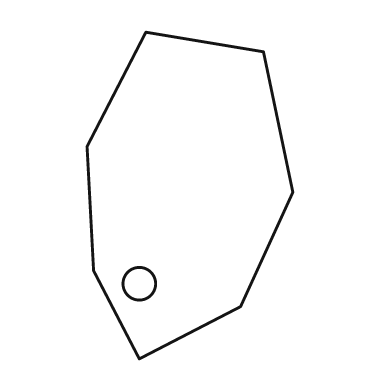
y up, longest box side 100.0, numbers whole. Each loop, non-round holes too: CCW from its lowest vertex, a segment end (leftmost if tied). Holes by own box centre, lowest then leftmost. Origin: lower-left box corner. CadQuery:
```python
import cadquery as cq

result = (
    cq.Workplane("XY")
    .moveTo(16.0, 0.0)
    .lineTo(47.0, 16.0)
    .lineTo(63.0, 51.0)
    .lineTo(54.0, 94.0)
    .lineTo(18.0, 100.0)
    .lineTo(0.0, 65.0)
    .lineTo(2.0, 27.0)
    .close()
    .moveTo(16.0, 23.0)
    .circle(5.0)
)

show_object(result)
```